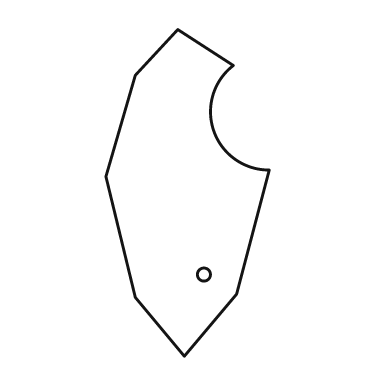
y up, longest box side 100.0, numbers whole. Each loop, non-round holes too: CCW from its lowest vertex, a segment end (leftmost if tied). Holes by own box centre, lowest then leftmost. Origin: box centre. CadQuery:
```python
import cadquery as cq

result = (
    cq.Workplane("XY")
    .moveTo(-1.0, -50.0)
    .lineTo(15.0, -31.0)
    .lineTo(25.0, 7.0)
    .threePointArc((8.0, 19.0), (14.0, 39.0))
    .lineTo(-3.0, 50.0)
    .lineTo(-16.0, 36.0)
    .lineTo(-25.0, 5.0)
    .lineTo(-16.0, -32.0)
    .close()
    .moveTo(5.0, -25.0)
    .circle(2.0)
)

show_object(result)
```